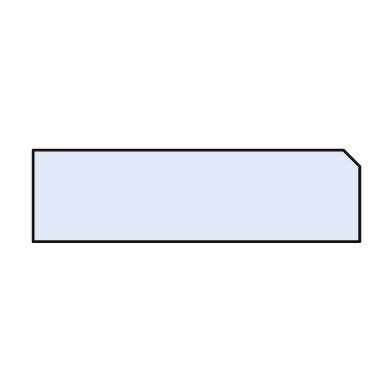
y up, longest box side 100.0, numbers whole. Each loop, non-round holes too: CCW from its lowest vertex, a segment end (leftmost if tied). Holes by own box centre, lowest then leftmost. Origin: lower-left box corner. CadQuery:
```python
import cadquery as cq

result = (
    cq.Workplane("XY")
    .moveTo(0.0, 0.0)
    .lineTo(100.0, 0.0)
    .lineTo(100.0, 23.0)
    .lineTo(95.0, 28.0)
    .lineTo(0.0, 28.0)
    .close()
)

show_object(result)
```